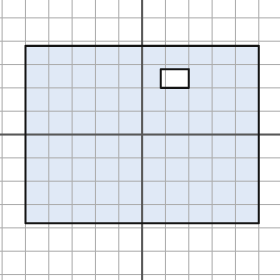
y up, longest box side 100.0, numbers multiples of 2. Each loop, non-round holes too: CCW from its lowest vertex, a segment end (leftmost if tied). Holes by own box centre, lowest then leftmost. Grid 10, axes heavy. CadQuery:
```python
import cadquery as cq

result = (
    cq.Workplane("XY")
    .moveTo(-50.0, -38.0)
    .lineTo(50.0, -38.0)
    .lineTo(50.0, 38.0)
    .lineTo(-50.0, 38.0)
    .close()
    .moveTo(8.0, 20.0)
    .lineTo(20.0, 20.0)
    .lineTo(20.0, 28.0)
    .lineTo(8.0, 28.0)
    .close()
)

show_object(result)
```